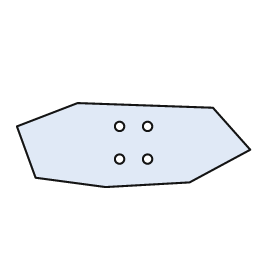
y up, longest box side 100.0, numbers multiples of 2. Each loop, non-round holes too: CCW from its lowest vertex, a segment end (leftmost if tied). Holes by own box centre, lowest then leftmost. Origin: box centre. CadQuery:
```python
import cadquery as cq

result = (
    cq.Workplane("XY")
    .moveTo(-12.0, -18.0)
    .lineTo(24.0, -16.0)
    .lineTo(50.0, -2.0)
    .lineTo(34.0, 16.0)
    .lineTo(-24.0, 18.0)
    .lineTo(-50.0, 8.0)
    .lineTo(-42.0, -14.0)
    .close()
    .moveTo(-6.0, -6.0)
    .circle(2.0)
    .moveTo(6.0, -6.0)
    .circle(2.0)
    .moveTo(-6.0, 8.0)
    .circle(2.0)
    .moveTo(6.0, 8.0)
    .circle(2.0)
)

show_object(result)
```